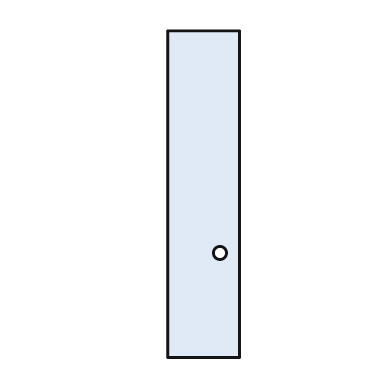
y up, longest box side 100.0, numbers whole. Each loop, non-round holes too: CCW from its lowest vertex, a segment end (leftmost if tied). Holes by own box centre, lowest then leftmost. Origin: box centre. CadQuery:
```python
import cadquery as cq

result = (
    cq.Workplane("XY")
    .moveTo(-11.0, -50.0)
    .lineTo(11.0, -50.0)
    .lineTo(11.0, 50.0)
    .lineTo(-11.0, 50.0)
    .close()
    .moveTo(5.0, -18.0)
    .circle(2.0)
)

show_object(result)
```